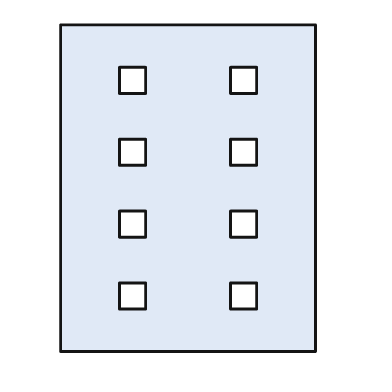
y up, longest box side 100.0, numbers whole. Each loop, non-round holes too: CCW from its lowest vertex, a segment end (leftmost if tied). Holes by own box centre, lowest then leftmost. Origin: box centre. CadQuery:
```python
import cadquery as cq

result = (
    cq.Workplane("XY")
    .moveTo(-39.0, -50.0)
    .lineTo(39.0, -50.0)
    .lineTo(39.0, 50.0)
    .lineTo(-39.0, 50.0)
    .close()
    .moveTo(-21.0, -37.0)
    .lineTo(-13.0, -37.0)
    .lineTo(-13.0, -29.0)
    .lineTo(-21.0, -29.0)
    .close()
    .moveTo(13.0, -37.0)
    .lineTo(21.0, -37.0)
    .lineTo(21.0, -29.0)
    .lineTo(13.0, -29.0)
    .close()
    .moveTo(-21.0, -15.0)
    .lineTo(-13.0, -15.0)
    .lineTo(-13.0, -7.0)
    .lineTo(-21.0, -7.0)
    .close()
    .moveTo(13.0, -15.0)
    .lineTo(21.0, -15.0)
    .lineTo(21.0, -7.0)
    .lineTo(13.0, -7.0)
    .close()
    .moveTo(-21.0, 7.0)
    .lineTo(-13.0, 7.0)
    .lineTo(-13.0, 15.0)
    .lineTo(-21.0, 15.0)
    .close()
    .moveTo(13.0, 7.0)
    .lineTo(21.0, 7.0)
    .lineTo(21.0, 15.0)
    .lineTo(13.0, 15.0)
    .close()
    .moveTo(-21.0, 29.0)
    .lineTo(-13.0, 29.0)
    .lineTo(-13.0, 37.0)
    .lineTo(-21.0, 37.0)
    .close()
    .moveTo(13.0, 29.0)
    .lineTo(21.0, 29.0)
    .lineTo(21.0, 37.0)
    .lineTo(13.0, 37.0)
    .close()
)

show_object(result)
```